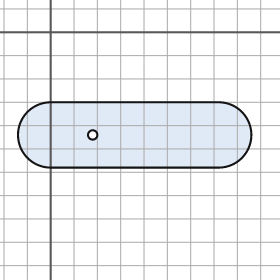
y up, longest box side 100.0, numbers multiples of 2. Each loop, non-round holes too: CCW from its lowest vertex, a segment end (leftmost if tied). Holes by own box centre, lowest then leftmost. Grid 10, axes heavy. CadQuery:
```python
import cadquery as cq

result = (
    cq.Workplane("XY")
    .moveTo(0.0, -58.0)
    .lineTo(72.0, -58.0)
    .threePointArc((86.0, -44.0), (72.0, -30.0))
    .lineTo(0.0, -30.0)
    .threePointArc((-14.0, -44.0), (0.0, -58.0))
    .close()
    .moveTo(18.0, -44.0)
    .circle(2.0)
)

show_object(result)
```